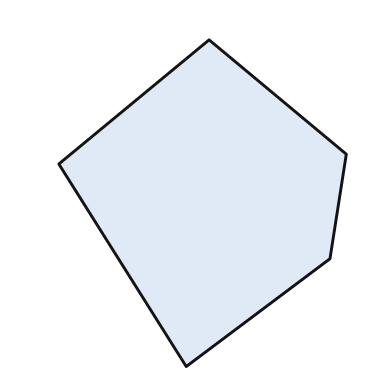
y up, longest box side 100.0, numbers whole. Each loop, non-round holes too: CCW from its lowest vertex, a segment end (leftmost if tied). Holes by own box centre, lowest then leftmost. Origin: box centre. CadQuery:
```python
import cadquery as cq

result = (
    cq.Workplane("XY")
    .moveTo(-5.0, -50.0)
    .lineTo(39.0, -17.0)
    .lineTo(44.0, 15.0)
    .lineTo(2.0, 50.0)
    .lineTo(-44.0, 12.0)
    .close()
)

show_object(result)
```